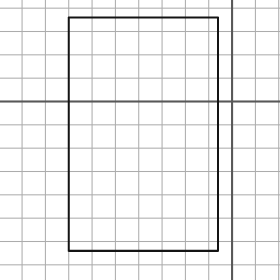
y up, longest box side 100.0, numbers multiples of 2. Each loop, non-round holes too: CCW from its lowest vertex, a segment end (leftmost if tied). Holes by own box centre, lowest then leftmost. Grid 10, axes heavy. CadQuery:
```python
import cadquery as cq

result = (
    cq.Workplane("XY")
    .moveTo(-70.0, -64.0)
    .lineTo(-6.0, -64.0)
    .lineTo(-6.0, 36.0)
    .lineTo(-70.0, 36.0)
    .close()
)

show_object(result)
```